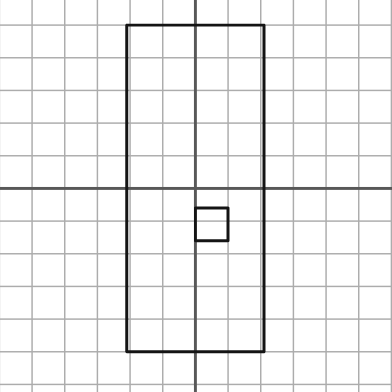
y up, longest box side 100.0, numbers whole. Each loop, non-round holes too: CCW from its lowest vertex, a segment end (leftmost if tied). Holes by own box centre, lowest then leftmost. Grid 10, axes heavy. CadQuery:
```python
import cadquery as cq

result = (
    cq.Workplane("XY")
    .moveTo(-21.0, -50.0)
    .lineTo(21.0, -50.0)
    .lineTo(21.0, 50.0)
    .lineTo(-21.0, 50.0)
    .close()
    .moveTo(0.0, -16.0)
    .lineTo(10.0, -16.0)
    .lineTo(10.0, -6.0)
    .lineTo(0.0, -6.0)
    .close()
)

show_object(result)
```